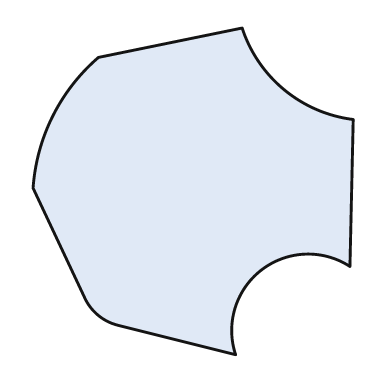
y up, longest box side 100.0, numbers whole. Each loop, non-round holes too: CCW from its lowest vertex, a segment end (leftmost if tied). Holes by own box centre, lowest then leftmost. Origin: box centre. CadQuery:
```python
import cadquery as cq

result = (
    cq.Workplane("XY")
    .moveTo(13.0, -50.0)
    .threePointArc((21.0, -24.0), (48.0, -23.0))
    .lineTo(49.0, 22.0)
    .threePointArc((28.0, 31.0), (15.0, 50.0))
    .lineTo(-29.0, 41.0)
    .threePointArc((-43.0, 23.0), (-49.0, 1.0))
    .lineTo(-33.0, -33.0)
    .threePointArc((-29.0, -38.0), (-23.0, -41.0))
    .close()
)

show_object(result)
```